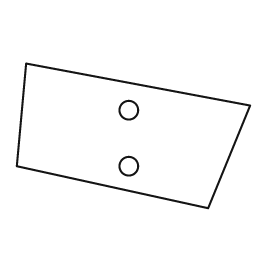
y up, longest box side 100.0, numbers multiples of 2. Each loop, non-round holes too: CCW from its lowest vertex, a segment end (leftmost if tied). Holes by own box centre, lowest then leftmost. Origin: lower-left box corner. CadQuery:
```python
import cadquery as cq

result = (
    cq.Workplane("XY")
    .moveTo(82.0, 0.0)
    .lineTo(100.0, 44.0)
    .lineTo(4.0, 62.0)
    .lineTo(0.0, 18.0)
    .close()
    .moveTo(48.0, 18.0)
    .circle(4.0)
    .moveTo(48.0, 42.0)
    .circle(4.0)
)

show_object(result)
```